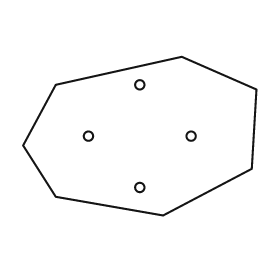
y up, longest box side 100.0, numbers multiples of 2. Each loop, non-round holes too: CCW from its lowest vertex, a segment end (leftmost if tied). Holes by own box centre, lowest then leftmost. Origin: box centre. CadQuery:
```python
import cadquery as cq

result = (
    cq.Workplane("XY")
    .moveTo(10.0, -34.0)
    .lineTo(48.0, -14.0)
    .lineTo(50.0, 20.0)
    .lineTo(18.0, 34.0)
    .lineTo(-36.0, 22.0)
    .lineTo(-50.0, -4.0)
    .lineTo(-36.0, -26.0)
    .close()
    .moveTo(0.0, -22.0)
    .circle(2.0)
    .moveTo(-22.0, 0.0)
    .circle(2.0)
    .moveTo(22.0, 0.0)
    .circle(2.0)
    .moveTo(0.0, 22.0)
    .circle(2.0)
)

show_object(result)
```